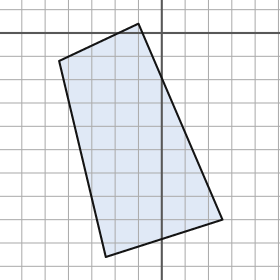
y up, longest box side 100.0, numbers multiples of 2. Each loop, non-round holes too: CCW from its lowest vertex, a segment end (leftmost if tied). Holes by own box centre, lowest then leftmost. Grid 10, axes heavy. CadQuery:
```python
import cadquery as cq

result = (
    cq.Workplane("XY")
    .moveTo(-24.0, -96.0)
    .lineTo(26.0, -80.0)
    .lineTo(-10.0, 4.0)
    .lineTo(-44.0, -12.0)
    .close()
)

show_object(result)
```